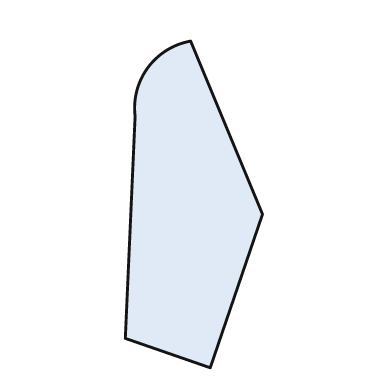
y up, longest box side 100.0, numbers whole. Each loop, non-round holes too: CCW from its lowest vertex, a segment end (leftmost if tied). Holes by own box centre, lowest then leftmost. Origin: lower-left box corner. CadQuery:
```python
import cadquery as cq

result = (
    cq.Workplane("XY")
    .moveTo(26.0, 0.0)
    .lineTo(42.0, 47.0)
    .lineTo(20.0, 100.0)
    .threePointArc((7.0, 92.0), (3.0, 77.0))
    .lineTo(0.0, 9.0)
    .close()
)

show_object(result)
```